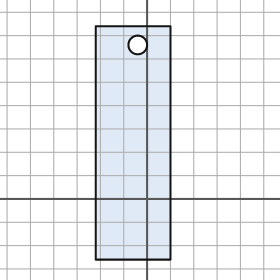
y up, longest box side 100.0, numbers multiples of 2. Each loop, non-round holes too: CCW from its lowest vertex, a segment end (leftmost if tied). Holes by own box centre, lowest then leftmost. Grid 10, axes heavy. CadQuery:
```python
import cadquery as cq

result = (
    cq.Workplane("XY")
    .moveTo(-22.0, -26.0)
    .lineTo(10.0, -26.0)
    .lineTo(10.0, 74.0)
    .lineTo(-22.0, 74.0)
    .close()
    .moveTo(-4.0, 66.0)
    .circle(4.0)
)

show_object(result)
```